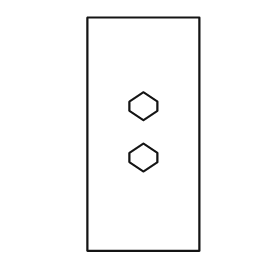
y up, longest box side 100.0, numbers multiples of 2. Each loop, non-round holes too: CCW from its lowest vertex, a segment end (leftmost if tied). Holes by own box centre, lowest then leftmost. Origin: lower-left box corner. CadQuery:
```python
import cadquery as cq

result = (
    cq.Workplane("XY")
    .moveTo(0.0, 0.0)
    .lineTo(48.0, 0.0)
    .lineTo(48.0, 100.0)
    .lineTo(0.0, 100.0)
    .close()
    .moveTo(24.0, 34.0)
    .lineTo(30.0, 38.0)
    .lineTo(30.0, 42.0)
    .lineTo(24.0, 46.0)
    .lineTo(18.0, 42.0)
    .lineTo(18.0, 38.0)
    .close()
    .moveTo(24.0, 56.0)
    .lineTo(30.0, 60.0)
    .lineTo(30.0, 64.0)
    .lineTo(24.0, 68.0)
    .lineTo(18.0, 64.0)
    .lineTo(18.0, 60.0)
    .close()
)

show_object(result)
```